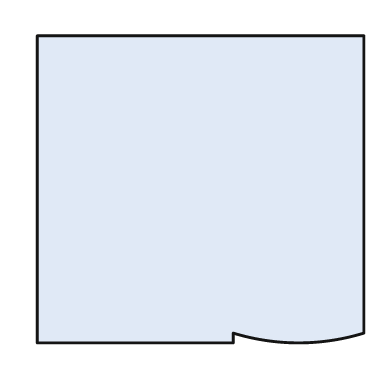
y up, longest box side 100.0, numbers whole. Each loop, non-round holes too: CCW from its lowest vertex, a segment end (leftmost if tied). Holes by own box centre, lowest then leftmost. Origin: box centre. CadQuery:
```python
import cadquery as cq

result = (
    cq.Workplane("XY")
    .moveTo(-50.0, -47.0)
    .lineTo(10.0, -47.0)
    .lineTo(10.0, -44.0)
    .threePointArc((30.0, -47.0), (50.0, -44.0))
    .lineTo(50.0, 47.0)
    .lineTo(-50.0, 47.0)
    .close()
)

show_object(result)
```